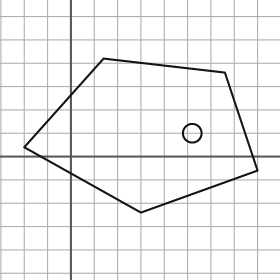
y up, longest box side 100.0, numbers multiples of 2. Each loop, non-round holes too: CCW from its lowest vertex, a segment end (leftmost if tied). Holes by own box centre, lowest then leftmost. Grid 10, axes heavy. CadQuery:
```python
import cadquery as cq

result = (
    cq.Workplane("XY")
    .moveTo(30.0, -24.0)
    .lineTo(80.0, -6.0)
    .lineTo(66.0, 36.0)
    .lineTo(14.0, 42.0)
    .lineTo(-20.0, 4.0)
    .close()
    .moveTo(52.0, 10.0)
    .circle(4.0)
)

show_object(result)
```